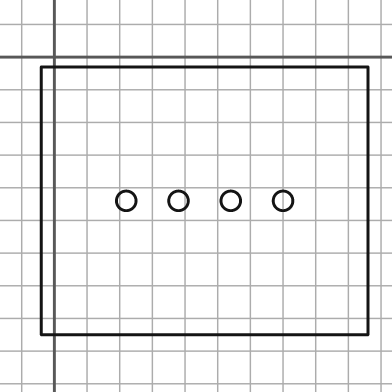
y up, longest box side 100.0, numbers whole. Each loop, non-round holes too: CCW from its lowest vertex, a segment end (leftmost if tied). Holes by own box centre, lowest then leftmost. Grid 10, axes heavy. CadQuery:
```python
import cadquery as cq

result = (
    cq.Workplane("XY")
    .moveTo(-4.0, -85.0)
    .lineTo(96.0, -85.0)
    .lineTo(96.0, -3.0)
    .lineTo(-4.0, -3.0)
    .close()
    .moveTo(22.0, -44.0)
    .circle(3.0)
    .moveTo(38.0, -44.0)
    .circle(3.0)
    .moveTo(54.0, -44.0)
    .circle(3.0)
    .moveTo(70.0, -44.0)
    .circle(3.0)
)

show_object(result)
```